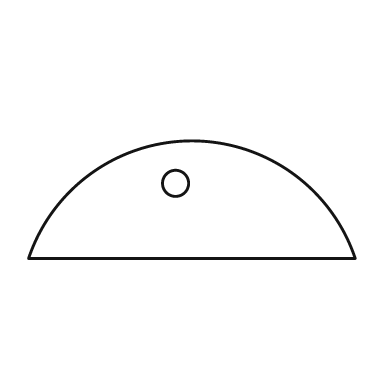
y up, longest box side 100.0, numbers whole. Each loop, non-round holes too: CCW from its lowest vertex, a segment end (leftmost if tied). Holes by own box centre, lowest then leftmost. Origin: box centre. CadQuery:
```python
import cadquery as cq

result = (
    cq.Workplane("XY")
    .moveTo(-50.0, -18.0)
    .lineTo(50.0, -18.0)
    .threePointArc((0.0, 18.0), (-50.0, -18.0))
    .close()
    .moveTo(-5.0, 5.0)
    .circle(4.0)
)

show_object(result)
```